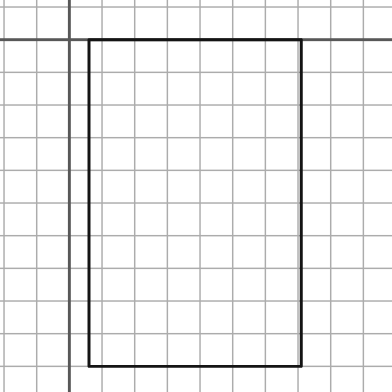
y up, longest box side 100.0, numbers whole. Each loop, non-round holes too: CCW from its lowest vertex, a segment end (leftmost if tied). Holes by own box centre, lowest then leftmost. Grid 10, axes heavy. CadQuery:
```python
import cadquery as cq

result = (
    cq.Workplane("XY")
    .moveTo(6.0, -100.0)
    .lineTo(71.0, -100.0)
    .lineTo(71.0, 0.0)
    .lineTo(6.0, 0.0)
    .close()
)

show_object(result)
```